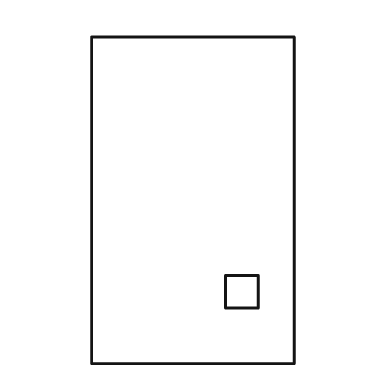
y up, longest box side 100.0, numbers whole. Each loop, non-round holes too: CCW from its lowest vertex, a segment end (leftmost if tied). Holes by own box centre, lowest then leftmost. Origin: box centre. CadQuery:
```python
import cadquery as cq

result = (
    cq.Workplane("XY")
    .moveTo(-31.0, -50.0)
    .lineTo(31.0, -50.0)
    .lineTo(31.0, 50.0)
    .lineTo(-31.0, 50.0)
    .close()
    .moveTo(10.0, -33.0)
    .lineTo(20.0, -33.0)
    .lineTo(20.0, -23.0)
    .lineTo(10.0, -23.0)
    .close()
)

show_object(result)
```